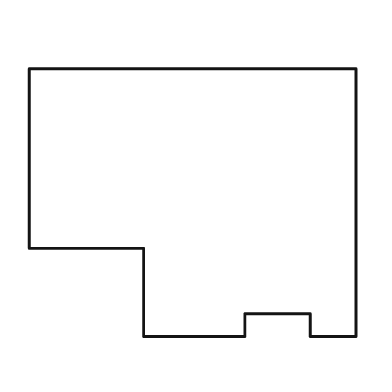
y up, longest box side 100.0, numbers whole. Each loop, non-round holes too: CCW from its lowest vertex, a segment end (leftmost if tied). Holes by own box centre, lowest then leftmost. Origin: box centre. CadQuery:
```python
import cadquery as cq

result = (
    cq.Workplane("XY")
    .moveTo(-15.0, -41.0)
    .lineTo(16.0, -41.0)
    .lineTo(16.0, -34.0)
    .lineTo(36.0, -34.0)
    .lineTo(36.0, -41.0)
    .lineTo(50.0, -41.0)
    .lineTo(50.0, 41.0)
    .lineTo(-50.0, 41.0)
    .lineTo(-50.0, -14.0)
    .lineTo(-15.0, -14.0)
    .close()
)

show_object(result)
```